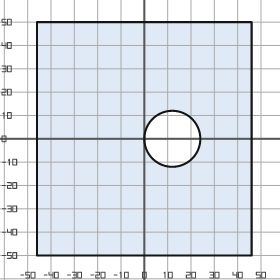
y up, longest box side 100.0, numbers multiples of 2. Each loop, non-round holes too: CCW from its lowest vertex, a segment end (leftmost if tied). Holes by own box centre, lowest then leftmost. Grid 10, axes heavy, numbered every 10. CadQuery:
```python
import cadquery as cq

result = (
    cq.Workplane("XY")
    .moveTo(-46.0, -50.0)
    .lineTo(46.0, -50.0)
    .lineTo(46.0, 50.0)
    .lineTo(-46.0, 50.0)
    .close()
    .moveTo(12.0, 0.0)
    .circle(12.0)
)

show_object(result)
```